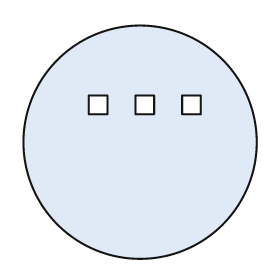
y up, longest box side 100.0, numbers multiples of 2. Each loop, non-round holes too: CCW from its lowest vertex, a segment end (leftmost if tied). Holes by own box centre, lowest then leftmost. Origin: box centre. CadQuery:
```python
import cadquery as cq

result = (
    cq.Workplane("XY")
    .moveTo(0.0, 0.0)
    .circle(50.0)
    .moveTo(-22.0, 12.0)
    .lineTo(-14.0, 12.0)
    .lineTo(-14.0, 20.0)
    .lineTo(-22.0, 20.0)
    .close()
    .moveTo(-2.0, 12.0)
    .lineTo(6.0, 12.0)
    .lineTo(6.0, 20.0)
    .lineTo(-2.0, 20.0)
    .close()
    .moveTo(18.0, 12.0)
    .lineTo(26.0, 12.0)
    .lineTo(26.0, 20.0)
    .lineTo(18.0, 20.0)
    .close()
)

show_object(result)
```